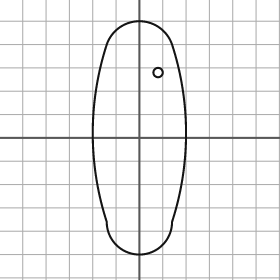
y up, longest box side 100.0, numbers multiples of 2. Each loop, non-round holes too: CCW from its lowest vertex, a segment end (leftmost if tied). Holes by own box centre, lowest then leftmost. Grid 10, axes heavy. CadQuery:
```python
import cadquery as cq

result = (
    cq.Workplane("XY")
    .moveTo(-14.0, -36.0)
    .threePointArc((0.0, -50.0), (14.0, -36.0))
    .threePointArc((20.0, 2.0), (14.0, 40.0))
    .threePointArc((0.0, 50.0), (-14.0, 40.0))
    .threePointArc((-20.0, 2.0), (-14.0, -36.0))
    .close()
    .moveTo(8.0, 28.0)
    .circle(2.0)
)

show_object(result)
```